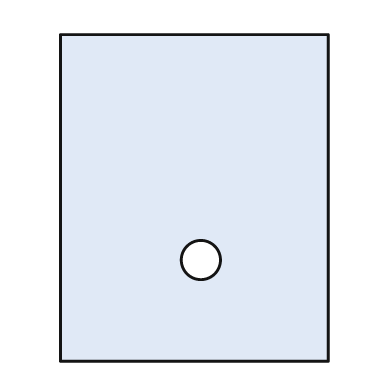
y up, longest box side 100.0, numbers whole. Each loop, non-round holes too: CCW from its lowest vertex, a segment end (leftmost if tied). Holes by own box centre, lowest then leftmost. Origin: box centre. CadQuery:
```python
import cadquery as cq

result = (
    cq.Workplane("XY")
    .moveTo(-41.0, -50.0)
    .lineTo(41.0, -50.0)
    .lineTo(41.0, 50.0)
    .lineTo(-41.0, 50.0)
    .close()
    .moveTo(2.0, -19.0)
    .circle(6.0)
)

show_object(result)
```